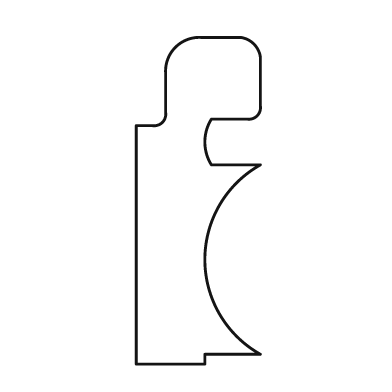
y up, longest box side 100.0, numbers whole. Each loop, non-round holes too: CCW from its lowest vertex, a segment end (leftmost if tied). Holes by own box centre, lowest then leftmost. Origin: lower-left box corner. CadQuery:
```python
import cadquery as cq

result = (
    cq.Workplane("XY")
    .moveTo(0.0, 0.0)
    .lineTo(21.0, 0.0)
    .lineTo(21.0, 3.0)
    .lineTo(38.0, 3.0)
    .threePointArc((21.0, 32.0), (38.0, 61.0))
    .lineTo(23.0, 61.0)
    .threePointArc((21.0, 68.0), (23.0, 75.0))
    .lineTo(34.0, 75.0)
    .threePointArc((37.0, 76.0), (38.0, 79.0))
    .lineTo(38.0, 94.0)
    .threePointArc((36.0, 98.0), (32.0, 100.0))
    .lineTo(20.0, 100.0)
    .threePointArc((12.0, 97.0), (9.0, 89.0))
    .lineTo(9.0, 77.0)
    .threePointArc((8.0, 74.0), (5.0, 73.0))
    .lineTo(0.0, 73.0)
    .close()
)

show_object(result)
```